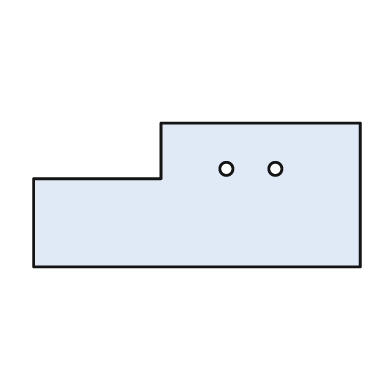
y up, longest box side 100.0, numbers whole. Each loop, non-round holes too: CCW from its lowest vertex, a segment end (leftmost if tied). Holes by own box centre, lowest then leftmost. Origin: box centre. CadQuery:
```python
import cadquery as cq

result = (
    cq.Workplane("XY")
    .moveTo(-50.0, -22.0)
    .lineTo(50.0, -22.0)
    .lineTo(50.0, 22.0)
    .lineTo(-11.0, 22.0)
    .lineTo(-11.0, 5.0)
    .lineTo(-50.0, 5.0)
    .close()
    .moveTo(9.0, 8.0)
    .circle(2.0)
    .moveTo(24.0, 8.0)
    .circle(2.0)
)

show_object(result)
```